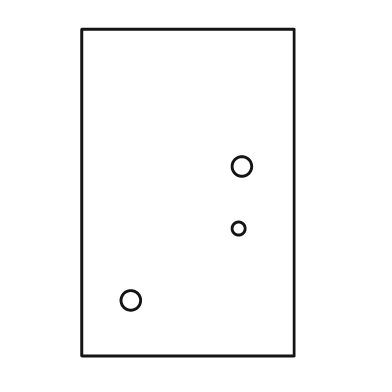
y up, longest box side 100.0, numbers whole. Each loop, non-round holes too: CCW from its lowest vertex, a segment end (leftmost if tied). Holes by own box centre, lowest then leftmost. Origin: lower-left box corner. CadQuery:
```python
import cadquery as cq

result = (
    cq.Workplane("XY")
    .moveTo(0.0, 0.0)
    .lineTo(65.0, 0.0)
    .lineTo(65.0, 100.0)
    .lineTo(0.0, 100.0)
    .close()
    .moveTo(15.0, 17.0)
    .circle(3.0)
    .moveTo(48.0, 39.0)
    .circle(2.0)
    .moveTo(49.0, 58.0)
    .circle(3.0)
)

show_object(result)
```